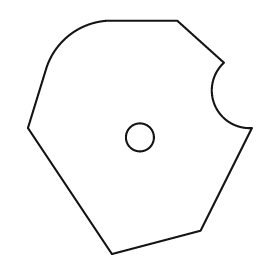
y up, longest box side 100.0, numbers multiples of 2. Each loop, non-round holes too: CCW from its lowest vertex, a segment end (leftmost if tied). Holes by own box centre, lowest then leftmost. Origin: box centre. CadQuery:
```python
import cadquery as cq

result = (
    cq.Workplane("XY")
    .moveTo(-12.0, -50.0)
    .lineTo(26.0, -40.0)
    .lineTo(48.0, 4.0)
    .threePointArc((32.0, 14.0), (36.0, 32.0))
    .lineTo(16.0, 50.0)
    .lineTo(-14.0, 50.0)
    .threePointArc((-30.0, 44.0), (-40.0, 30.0))
    .lineTo(-48.0, 4.0)
    .close()
    .moveTo(0.0, 0.0)
    .circle(6.0)
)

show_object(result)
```